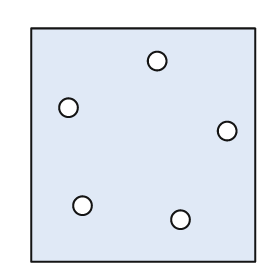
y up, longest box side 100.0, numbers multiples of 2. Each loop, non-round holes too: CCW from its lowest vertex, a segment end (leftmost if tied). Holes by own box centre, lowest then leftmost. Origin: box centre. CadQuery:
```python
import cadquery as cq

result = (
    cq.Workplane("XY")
    .moveTo(-48.0, -50.0)
    .lineTo(48.0, -50.0)
    .lineTo(48.0, 50.0)
    .lineTo(-48.0, 50.0)
    .close()
    .moveTo(16.0, -32.0)
    .circle(4.0)
    .moveTo(-26.0, -26.0)
    .circle(4.0)
    .moveTo(36.0, 6.0)
    .circle(4.0)
    .moveTo(-32.0, 16.0)
    .circle(4.0)
    .moveTo(6.0, 36.0)
    .circle(4.0)
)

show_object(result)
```